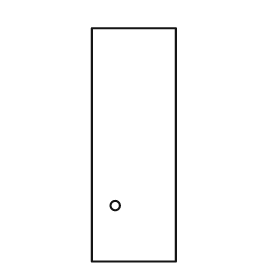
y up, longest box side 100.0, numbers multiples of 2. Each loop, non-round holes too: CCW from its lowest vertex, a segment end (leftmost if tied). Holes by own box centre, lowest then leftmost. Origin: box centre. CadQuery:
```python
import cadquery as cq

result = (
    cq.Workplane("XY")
    .moveTo(-18.0, -50.0)
    .lineTo(18.0, -50.0)
    .lineTo(18.0, 50.0)
    .lineTo(-18.0, 50.0)
    .close()
    .moveTo(-8.0, -26.0)
    .circle(2.0)
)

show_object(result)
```